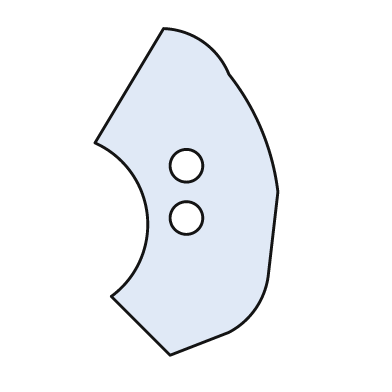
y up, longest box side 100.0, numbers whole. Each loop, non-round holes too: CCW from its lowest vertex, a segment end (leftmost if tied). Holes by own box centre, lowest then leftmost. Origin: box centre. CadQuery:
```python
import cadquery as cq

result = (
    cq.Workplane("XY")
    .moveTo(-5.0, -50.0)
    .lineTo(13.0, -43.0)
    .threePointArc((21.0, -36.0), (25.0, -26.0))
    .lineTo(28.0, 0.0)
    .threePointArc((23.0, 19.0), (13.0, 36.0))
    .threePointArc((5.0, 46.0), (-7.0, 50.0))
    .lineTo(-28.0, 15.0)
    .threePointArc((-12.0, -7.0), (-23.0, -32.0))
    .close()
    .moveTo(0.0, -8.0)
    .circle(5.0)
    .moveTo(0.0, 8.0)
    .circle(5.0)
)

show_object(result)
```